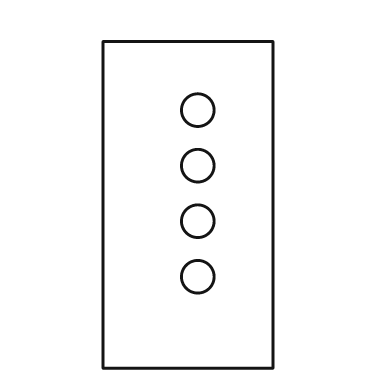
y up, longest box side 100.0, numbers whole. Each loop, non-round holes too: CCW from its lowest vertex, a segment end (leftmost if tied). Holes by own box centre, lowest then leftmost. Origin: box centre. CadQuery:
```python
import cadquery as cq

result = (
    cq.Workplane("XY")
    .moveTo(-26.0, -50.0)
    .lineTo(26.0, -50.0)
    .lineTo(26.0, 50.0)
    .lineTo(-26.0, 50.0)
    .close()
    .moveTo(3.0, -22.0)
    .circle(5.0)
    .moveTo(3.0, -5.0)
    .circle(5.0)
    .moveTo(3.0, 12.0)
    .circle(5.0)
    .moveTo(3.0, 29.0)
    .circle(5.0)
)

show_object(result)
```